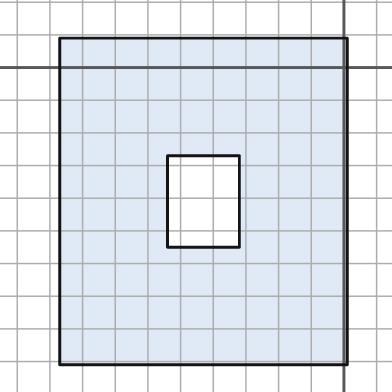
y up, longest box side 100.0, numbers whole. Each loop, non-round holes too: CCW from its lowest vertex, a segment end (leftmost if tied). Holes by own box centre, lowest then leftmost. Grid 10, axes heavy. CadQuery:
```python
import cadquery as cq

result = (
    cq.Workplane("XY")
    .moveTo(-87.0, -91.0)
    .lineTo(1.0, -91.0)
    .lineTo(1.0, 9.0)
    .lineTo(-87.0, 9.0)
    .close()
    .moveTo(-54.0, -55.0)
    .lineTo(-32.0, -55.0)
    .lineTo(-32.0, -27.0)
    .lineTo(-54.0, -27.0)
    .close()
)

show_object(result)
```